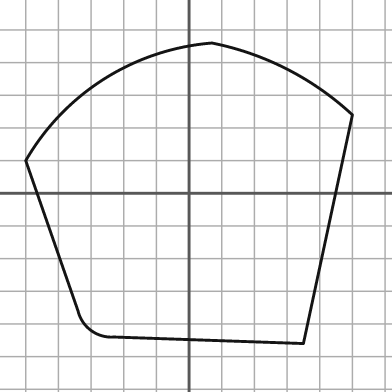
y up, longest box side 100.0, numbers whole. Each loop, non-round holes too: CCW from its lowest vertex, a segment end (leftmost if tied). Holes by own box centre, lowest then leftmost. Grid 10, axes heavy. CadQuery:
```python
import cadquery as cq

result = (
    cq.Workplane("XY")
    .moveTo(35.0, -46.0)
    .lineTo(50.0, 24.0)
    .threePointArc((30.0, 38.0), (7.0, 46.0))
    .threePointArc((-26.0, 35.0), (-50.0, 10.0))
    .lineTo(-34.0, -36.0)
    .threePointArc((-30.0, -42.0), (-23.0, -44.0))
    .close()
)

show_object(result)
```